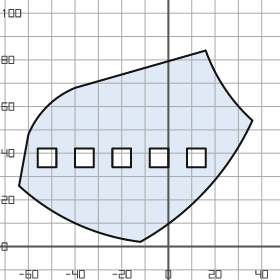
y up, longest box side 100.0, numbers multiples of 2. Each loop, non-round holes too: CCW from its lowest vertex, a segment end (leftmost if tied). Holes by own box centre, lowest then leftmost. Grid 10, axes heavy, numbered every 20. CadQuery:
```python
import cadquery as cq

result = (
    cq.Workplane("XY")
    .moveTo(-12.0, 2.0)
    .threePointArc((16.0, 24.0), (36.0, 54.0))
    .threePointArc((24.0, 68.0), (16.0, 84.0))
    .lineTo(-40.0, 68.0)
    .threePointArc((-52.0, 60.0), (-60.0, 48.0))
    .lineTo(-64.0, 26.0)
    .threePointArc((-40.0, 10.0), (-12.0, 2.0))
    .close()
    .moveTo(-56.0, 34.0)
    .lineTo(-48.0, 34.0)
    .lineTo(-48.0, 42.0)
    .lineTo(-56.0, 42.0)
    .close()
    .moveTo(-40.0, 34.0)
    .lineTo(-32.0, 34.0)
    .lineTo(-32.0, 42.0)
    .lineTo(-40.0, 42.0)
    .close()
    .moveTo(-24.0, 34.0)
    .lineTo(-16.0, 34.0)
    .lineTo(-16.0, 42.0)
    .lineTo(-24.0, 42.0)
    .close()
    .moveTo(-8.0, 34.0)
    .lineTo(0.0, 34.0)
    .lineTo(0.0, 42.0)
    .lineTo(-8.0, 42.0)
    .close()
    .moveTo(8.0, 34.0)
    .lineTo(16.0, 34.0)
    .lineTo(16.0, 42.0)
    .lineTo(8.0, 42.0)
    .close()
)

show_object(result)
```